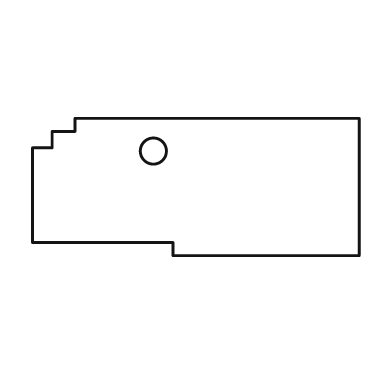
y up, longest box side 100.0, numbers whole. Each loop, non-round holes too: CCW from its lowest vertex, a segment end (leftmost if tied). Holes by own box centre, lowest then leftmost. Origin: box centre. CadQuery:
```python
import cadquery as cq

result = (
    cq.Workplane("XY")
    .moveTo(-7.0, -21.0)
    .lineTo(50.0, -21.0)
    .lineTo(50.0, 21.0)
    .lineTo(-37.0, 21.0)
    .lineTo(-37.0, 17.0)
    .lineTo(-44.0, 17.0)
    .lineTo(-44.0, 12.0)
    .lineTo(-50.0, 12.0)
    .lineTo(-50.0, -17.0)
    .lineTo(-7.0, -17.0)
    .close()
    .moveTo(-13.0, 11.0)
    .circle(4.0)
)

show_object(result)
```